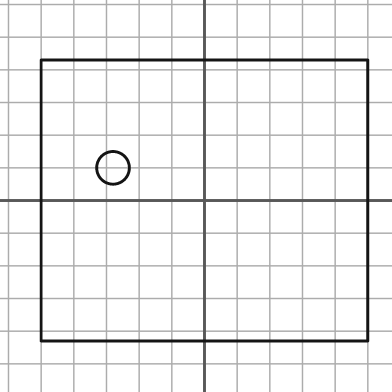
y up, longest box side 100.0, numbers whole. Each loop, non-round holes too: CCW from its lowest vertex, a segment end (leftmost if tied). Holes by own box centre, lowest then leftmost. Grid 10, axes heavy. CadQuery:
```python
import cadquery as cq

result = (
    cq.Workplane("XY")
    .moveTo(-50.0, -43.0)
    .lineTo(50.0, -43.0)
    .lineTo(50.0, 43.0)
    .lineTo(-50.0, 43.0)
    .close()
    .moveTo(-28.0, 10.0)
    .circle(5.0)
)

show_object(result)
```